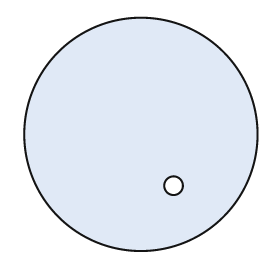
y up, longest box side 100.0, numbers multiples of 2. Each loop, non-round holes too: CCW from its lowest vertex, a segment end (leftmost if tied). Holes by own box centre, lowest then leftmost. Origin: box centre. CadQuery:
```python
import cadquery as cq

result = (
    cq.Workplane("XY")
    .moveTo(0.0, 0.0)
    .circle(50.0)
    .moveTo(14.0, -22.0)
    .circle(4.0)
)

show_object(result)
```